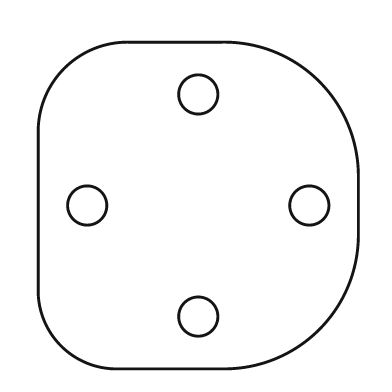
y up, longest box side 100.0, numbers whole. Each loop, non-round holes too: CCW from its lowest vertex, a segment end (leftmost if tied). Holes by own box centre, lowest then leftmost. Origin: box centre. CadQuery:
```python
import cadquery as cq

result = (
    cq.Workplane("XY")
    .moveTo(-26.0, -50.0)
    .lineTo(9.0, -50.0)
    .threePointArc((37.0, -38.0), (49.0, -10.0))
    .lineTo(49.0, 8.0)
    .threePointArc((37.0, 38.0), (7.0, 50.0))
    .lineTo(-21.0, 50.0)
    .threePointArc((-41.0, 42.0), (-49.0, 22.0))
    .lineTo(-49.0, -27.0)
    .threePointArc((-42.0, -43.0), (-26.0, -50.0))
    .close()
    .moveTo(0.0, -34.0)
    .circle(6.0)
    .moveTo(-34.0, 0.0)
    .circle(6.0)
    .moveTo(34.0, 0.0)
    .circle(6.0)
    .moveTo(0.0, 34.0)
    .circle(6.0)
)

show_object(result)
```